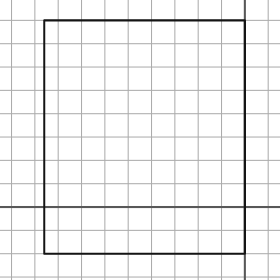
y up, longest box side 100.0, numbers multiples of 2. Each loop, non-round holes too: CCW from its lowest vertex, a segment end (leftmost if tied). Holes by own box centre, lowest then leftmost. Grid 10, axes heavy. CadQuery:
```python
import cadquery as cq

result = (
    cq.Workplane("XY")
    .moveTo(-86.0, -20.0)
    .lineTo(0.0, -20.0)
    .lineTo(0.0, 80.0)
    .lineTo(-86.0, 80.0)
    .close()
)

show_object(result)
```